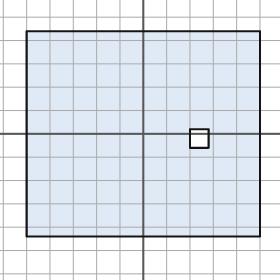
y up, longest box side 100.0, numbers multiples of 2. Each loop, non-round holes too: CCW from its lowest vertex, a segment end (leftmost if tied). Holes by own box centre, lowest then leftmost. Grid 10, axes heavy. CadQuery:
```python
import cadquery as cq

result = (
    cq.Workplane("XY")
    .moveTo(-50.0, -44.0)
    .lineTo(50.0, -44.0)
    .lineTo(50.0, 44.0)
    .lineTo(-50.0, 44.0)
    .close()
    .moveTo(20.0, -6.0)
    .lineTo(28.0, -6.0)
    .lineTo(28.0, 2.0)
    .lineTo(20.0, 2.0)
    .close()
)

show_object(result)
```